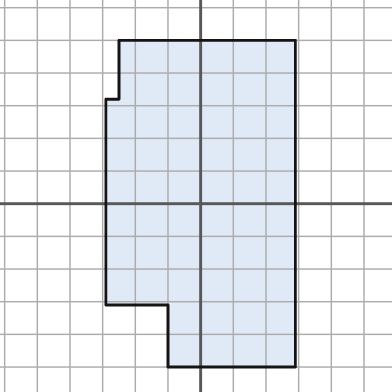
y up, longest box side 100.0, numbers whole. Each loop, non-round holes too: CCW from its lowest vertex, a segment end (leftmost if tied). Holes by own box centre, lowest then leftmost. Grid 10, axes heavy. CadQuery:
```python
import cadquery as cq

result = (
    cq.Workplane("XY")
    .moveTo(-10.0, -50.0)
    .lineTo(29.0, -50.0)
    .lineTo(29.0, 50.0)
    .lineTo(-25.0, 50.0)
    .lineTo(-25.0, 32.0)
    .lineTo(-29.0, 32.0)
    .lineTo(-29.0, -31.0)
    .lineTo(-10.0, -31.0)
    .close()
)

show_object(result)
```